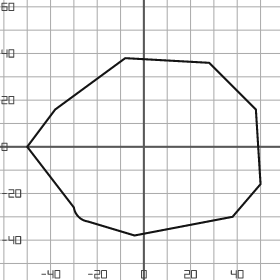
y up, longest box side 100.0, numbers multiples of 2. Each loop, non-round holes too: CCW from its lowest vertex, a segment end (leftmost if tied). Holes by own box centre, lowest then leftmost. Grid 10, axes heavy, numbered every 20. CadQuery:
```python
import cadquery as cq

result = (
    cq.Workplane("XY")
    .moveTo(-4.0, -38.0)
    .lineTo(38.0, -30.0)
    .lineTo(50.0, -16.0)
    .lineTo(48.0, 16.0)
    .lineTo(28.0, 36.0)
    .lineTo(-8.0, 38.0)
    .lineTo(-38.0, 16.0)
    .lineTo(-50.0, 0.0)
    .lineTo(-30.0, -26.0)
    .threePointArc((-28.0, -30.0), (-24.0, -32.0))
    .close()
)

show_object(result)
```